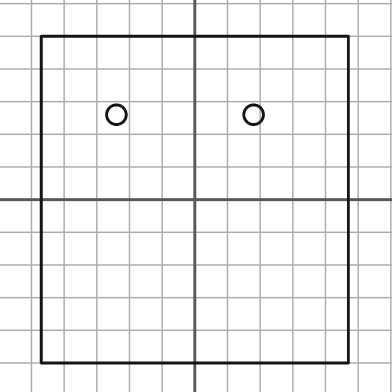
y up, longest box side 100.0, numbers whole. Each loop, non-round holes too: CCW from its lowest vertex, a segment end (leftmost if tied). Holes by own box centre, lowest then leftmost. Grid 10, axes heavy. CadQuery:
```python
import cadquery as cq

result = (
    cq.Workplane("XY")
    .moveTo(-47.0, -50.0)
    .lineTo(47.0, -50.0)
    .lineTo(47.0, 50.0)
    .lineTo(-47.0, 50.0)
    .close()
    .moveTo(-24.0, 26.0)
    .circle(3.0)
    .moveTo(18.0, 26.0)
    .circle(3.0)
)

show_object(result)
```